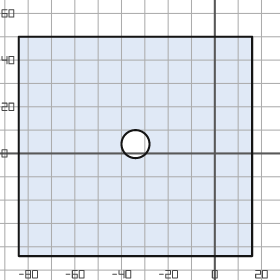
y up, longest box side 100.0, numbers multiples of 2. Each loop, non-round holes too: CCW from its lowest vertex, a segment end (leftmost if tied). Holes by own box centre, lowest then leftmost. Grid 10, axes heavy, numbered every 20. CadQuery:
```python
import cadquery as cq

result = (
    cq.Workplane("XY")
    .moveTo(-84.0, -44.0)
    .lineTo(16.0, -44.0)
    .lineTo(16.0, 50.0)
    .lineTo(-84.0, 50.0)
    .close()
    .moveTo(-34.0, 4.0)
    .circle(6.0)
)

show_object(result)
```